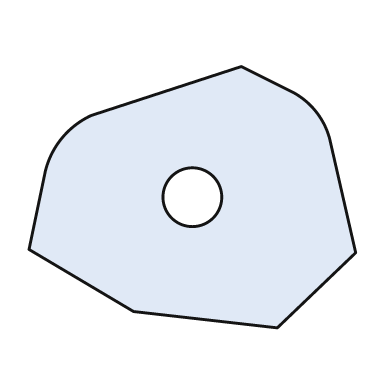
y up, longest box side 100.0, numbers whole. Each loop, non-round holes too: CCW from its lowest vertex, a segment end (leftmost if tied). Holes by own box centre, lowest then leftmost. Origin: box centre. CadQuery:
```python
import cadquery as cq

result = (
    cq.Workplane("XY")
    .moveTo(26.0, -40.0)
    .lineTo(50.0, -17.0)
    .lineTo(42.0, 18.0)
    .threePointArc((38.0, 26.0), (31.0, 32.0))
    .lineTo(15.0, 40.0)
    .lineTo(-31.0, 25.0)
    .threePointArc((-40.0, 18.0), (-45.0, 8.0))
    .lineTo(-50.0, -16.0)
    .lineTo(-18.0, -35.0)
    .close()
    .moveTo(0.0, 0.0)
    .circle(9.0)
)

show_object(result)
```